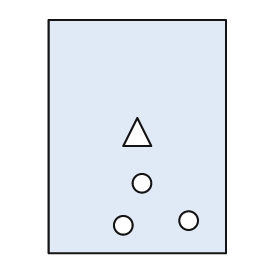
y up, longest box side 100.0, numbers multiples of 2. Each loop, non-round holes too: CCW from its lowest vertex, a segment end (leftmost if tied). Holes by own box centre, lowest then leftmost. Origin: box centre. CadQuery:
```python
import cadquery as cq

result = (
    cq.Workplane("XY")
    .moveTo(-38.0, -50.0)
    .lineTo(38.0, -50.0)
    .lineTo(38.0, 50.0)
    .lineTo(-38.0, 50.0)
    .close()
    .moveTo(-6.0, -38.0)
    .circle(4.0)
    .moveTo(22.0, -36.0)
    .circle(4.0)
    .moveTo(2.0, -20.0)
    .circle(4.0)
    .moveTo(-6.0, -4.0)
    .lineTo(6.0, -4.0)
    .lineTo(0.0, 8.0)
    .close()
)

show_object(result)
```